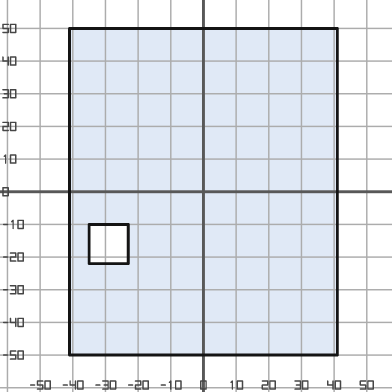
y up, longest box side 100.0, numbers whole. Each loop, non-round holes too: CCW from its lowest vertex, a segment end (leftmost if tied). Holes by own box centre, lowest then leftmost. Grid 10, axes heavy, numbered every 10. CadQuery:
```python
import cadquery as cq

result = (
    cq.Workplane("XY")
    .moveTo(-41.0, -50.0)
    .lineTo(41.0, -50.0)
    .lineTo(41.0, 50.0)
    .lineTo(-41.0, 50.0)
    .close()
    .moveTo(-35.0, -22.0)
    .lineTo(-23.0, -22.0)
    .lineTo(-23.0, -10.0)
    .lineTo(-35.0, -10.0)
    .close()
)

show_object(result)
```